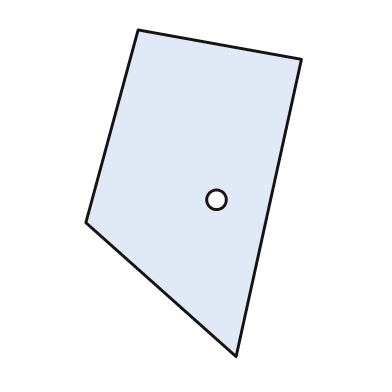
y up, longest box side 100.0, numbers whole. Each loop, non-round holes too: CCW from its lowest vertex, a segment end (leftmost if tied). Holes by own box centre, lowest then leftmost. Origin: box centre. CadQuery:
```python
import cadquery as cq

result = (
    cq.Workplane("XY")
    .moveTo(13.0, -50.0)
    .lineTo(33.0, 41.0)
    .lineTo(-17.0, 50.0)
    .lineTo(-33.0, -9.0)
    .close()
    .moveTo(7.0, -2.0)
    .circle(3.0)
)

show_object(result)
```